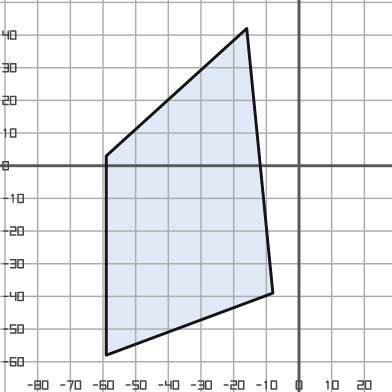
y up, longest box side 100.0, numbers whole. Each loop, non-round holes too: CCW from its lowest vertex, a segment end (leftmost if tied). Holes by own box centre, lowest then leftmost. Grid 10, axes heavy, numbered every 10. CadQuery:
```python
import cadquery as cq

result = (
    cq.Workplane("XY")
    .moveTo(-59.0, -58.0)
    .lineTo(-8.0, -39.0)
    .lineTo(-16.0, 42.0)
    .lineTo(-59.0, 3.0)
    .close()
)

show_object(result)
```